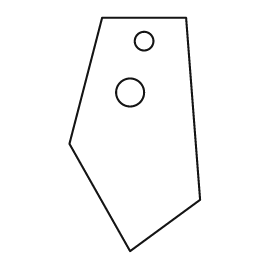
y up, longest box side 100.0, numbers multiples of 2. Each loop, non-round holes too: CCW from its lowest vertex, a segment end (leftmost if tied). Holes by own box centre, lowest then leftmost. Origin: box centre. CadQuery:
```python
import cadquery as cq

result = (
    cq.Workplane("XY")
    .moveTo(-2.0, -50.0)
    .lineTo(28.0, -28.0)
    .lineTo(22.0, 50.0)
    .lineTo(-14.0, 50.0)
    .lineTo(-28.0, -4.0)
    .close()
    .moveTo(-2.0, 18.0)
    .circle(6.0)
    .moveTo(4.0, 40.0)
    .circle(4.0)
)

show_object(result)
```